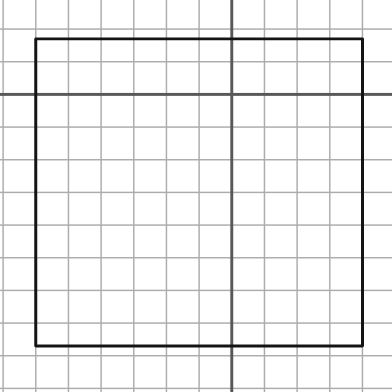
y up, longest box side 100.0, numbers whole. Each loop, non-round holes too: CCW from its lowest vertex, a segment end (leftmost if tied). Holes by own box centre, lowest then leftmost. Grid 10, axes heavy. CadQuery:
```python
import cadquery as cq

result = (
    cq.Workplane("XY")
    .moveTo(-60.0, -77.0)
    .lineTo(40.0, -77.0)
    .lineTo(40.0, 17.0)
    .lineTo(-60.0, 17.0)
    .close()
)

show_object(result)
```